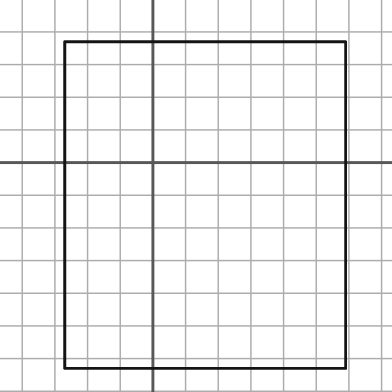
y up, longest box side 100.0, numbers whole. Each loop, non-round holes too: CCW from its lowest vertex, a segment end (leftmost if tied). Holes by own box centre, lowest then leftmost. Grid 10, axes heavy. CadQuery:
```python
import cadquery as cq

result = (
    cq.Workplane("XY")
    .moveTo(-27.0, -63.0)
    .lineTo(59.0, -63.0)
    .lineTo(59.0, 37.0)
    .lineTo(-27.0, 37.0)
    .close()
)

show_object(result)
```